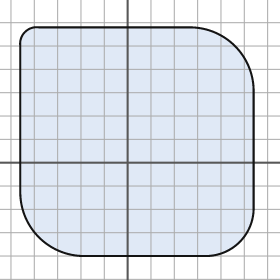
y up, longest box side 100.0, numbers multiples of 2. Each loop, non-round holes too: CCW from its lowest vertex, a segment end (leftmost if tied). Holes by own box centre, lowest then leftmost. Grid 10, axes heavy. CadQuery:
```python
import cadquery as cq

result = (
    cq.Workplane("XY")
    .moveTo(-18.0, -40.0)
    .lineTo(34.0, -40.0)
    .threePointArc((48.0, -34.0), (54.0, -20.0))
    .lineTo(54.0, 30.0)
    .threePointArc((46.0, 50.0), (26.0, 58.0))
    .lineTo(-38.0, 58.0)
    .threePointArc((-44.0, 56.0), (-46.0, 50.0))
    .lineTo(-46.0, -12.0)
    .threePointArc((-38.0, -32.0), (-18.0, -40.0))
    .close()
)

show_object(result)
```